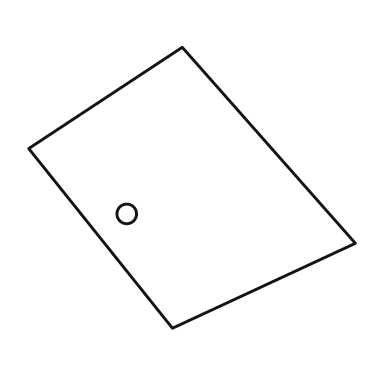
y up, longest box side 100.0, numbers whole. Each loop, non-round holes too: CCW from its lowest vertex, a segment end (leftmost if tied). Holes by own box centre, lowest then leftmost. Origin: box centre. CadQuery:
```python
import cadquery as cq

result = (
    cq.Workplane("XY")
    .moveTo(-6.0, -43.0)
    .lineTo(50.0, -17.0)
    .lineTo(-3.0, 43.0)
    .lineTo(-50.0, 12.0)
    .close()
    .moveTo(-20.0, -8.0)
    .circle(3.0)
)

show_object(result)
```